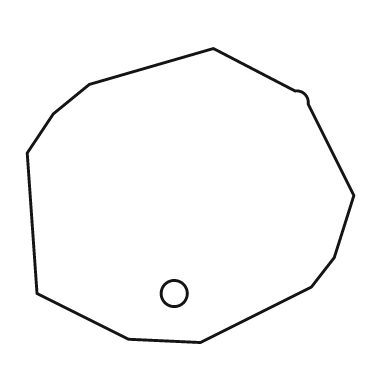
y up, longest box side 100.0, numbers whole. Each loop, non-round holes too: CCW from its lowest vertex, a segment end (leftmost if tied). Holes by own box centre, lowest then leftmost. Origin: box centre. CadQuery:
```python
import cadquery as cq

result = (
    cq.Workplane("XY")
    .moveTo(3.0, -45.0)
    .lineTo(37.0, -28.0)
    .lineTo(44.0, -19.0)
    .lineTo(50.0, 0.0)
    .lineTo(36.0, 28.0)
    .threePointArc((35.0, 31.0), (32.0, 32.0))
    .lineTo(7.0, 45.0)
    .lineTo(-31.0, 34.0)
    .lineTo(-42.0, 25.0)
    .lineTo(-50.0, 13.0)
    .lineTo(-47.0, -30.0)
    .lineTo(-19.0, -44.0)
    .close()
    .moveTo(-5.0, -30.0)
    .circle(4.0)
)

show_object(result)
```